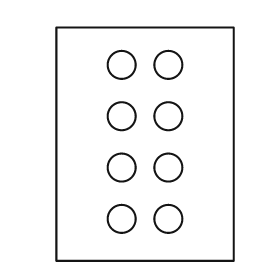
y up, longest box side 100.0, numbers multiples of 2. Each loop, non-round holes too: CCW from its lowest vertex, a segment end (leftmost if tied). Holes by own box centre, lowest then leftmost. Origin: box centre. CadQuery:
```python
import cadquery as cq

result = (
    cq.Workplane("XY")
    .moveTo(-38.0, -50.0)
    .lineTo(38.0, -50.0)
    .lineTo(38.0, 50.0)
    .lineTo(-38.0, 50.0)
    .close()
    .moveTo(-10.0, -32.0)
    .circle(6.0)
    .moveTo(10.0, -32.0)
    .circle(6.0)
    .moveTo(-10.0, -10.0)
    .circle(6.0)
    .moveTo(10.0, -10.0)
    .circle(6.0)
    .moveTo(-10.0, 12.0)
    .circle(6.0)
    .moveTo(10.0, 12.0)
    .circle(6.0)
    .moveTo(-10.0, 34.0)
    .circle(6.0)
    .moveTo(10.0, 34.0)
    .circle(6.0)
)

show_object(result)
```